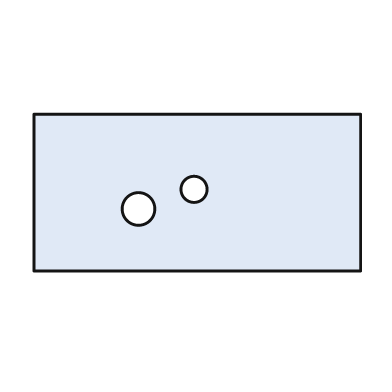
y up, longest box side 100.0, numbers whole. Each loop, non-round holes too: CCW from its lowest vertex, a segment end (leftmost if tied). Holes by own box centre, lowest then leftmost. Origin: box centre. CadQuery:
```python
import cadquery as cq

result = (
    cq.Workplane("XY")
    .moveTo(-50.0, -24.0)
    .lineTo(50.0, -24.0)
    .lineTo(50.0, 24.0)
    .lineTo(-50.0, 24.0)
    .close()
    .moveTo(-18.0, -5.0)
    .circle(5.0)
    .moveTo(-1.0, 1.0)
    .circle(4.0)
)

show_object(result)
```